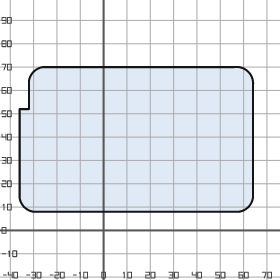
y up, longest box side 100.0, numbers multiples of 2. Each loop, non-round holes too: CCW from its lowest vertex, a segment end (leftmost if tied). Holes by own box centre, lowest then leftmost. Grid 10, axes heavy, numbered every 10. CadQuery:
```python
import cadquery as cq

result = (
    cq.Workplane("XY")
    .moveTo(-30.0, 8.0)
    .lineTo(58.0, 8.0)
    .threePointArc((62.0, 10.0), (64.0, 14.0))
    .lineTo(64.0, 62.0)
    .threePointArc((62.0, 68.0), (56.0, 70.0))
    .lineTo(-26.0, 70.0)
    .threePointArc((-30.0, 68.0), (-32.0, 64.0))
    .lineTo(-32.0, 52.0)
    .lineTo(-36.0, 52.0)
    .lineTo(-36.0, 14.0)
    .threePointArc((-34.0, 10.0), (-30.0, 8.0))
    .close()
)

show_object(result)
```